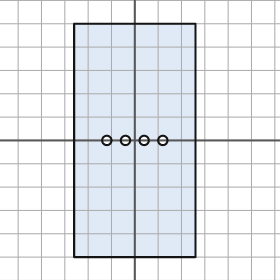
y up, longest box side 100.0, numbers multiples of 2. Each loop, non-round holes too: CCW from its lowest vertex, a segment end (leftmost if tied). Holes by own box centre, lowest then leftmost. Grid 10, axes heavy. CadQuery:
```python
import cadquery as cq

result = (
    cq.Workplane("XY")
    .moveTo(-26.0, -50.0)
    .lineTo(26.0, -50.0)
    .lineTo(26.0, 50.0)
    .lineTo(-26.0, 50.0)
    .close()
    .moveTo(-12.0, 0.0)
    .circle(2.0)
    .moveTo(-4.0, 0.0)
    .circle(2.0)
    .moveTo(4.0, 0.0)
    .circle(2.0)
    .moveTo(12.0, 0.0)
    .circle(2.0)
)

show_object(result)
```